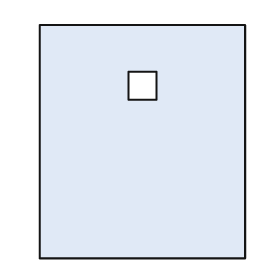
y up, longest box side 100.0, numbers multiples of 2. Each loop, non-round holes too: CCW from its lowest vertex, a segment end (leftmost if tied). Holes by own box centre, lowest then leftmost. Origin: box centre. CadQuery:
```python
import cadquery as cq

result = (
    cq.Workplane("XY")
    .moveTo(-44.0, -50.0)
    .lineTo(44.0, -50.0)
    .lineTo(44.0, 50.0)
    .lineTo(-44.0, 50.0)
    .close()
    .moveTo(-6.0, 18.0)
    .lineTo(6.0, 18.0)
    .lineTo(6.0, 30.0)
    .lineTo(-6.0, 30.0)
    .close()
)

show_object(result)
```